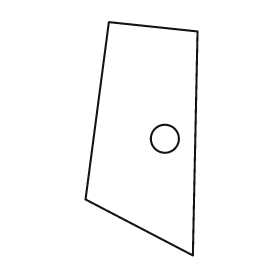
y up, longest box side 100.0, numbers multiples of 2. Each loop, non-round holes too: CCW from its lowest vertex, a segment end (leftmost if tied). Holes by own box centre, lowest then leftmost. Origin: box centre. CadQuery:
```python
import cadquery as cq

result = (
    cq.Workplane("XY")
    .moveTo(22.0, -50.0)
    .lineTo(24.0, 46.0)
    .lineTo(-14.0, 50.0)
    .lineTo(-24.0, -26.0)
    .close()
    .moveTo(10.0, 0.0)
    .circle(6.0)
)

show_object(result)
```